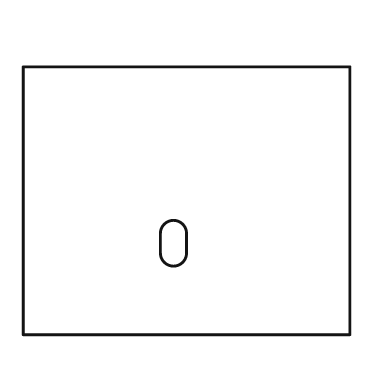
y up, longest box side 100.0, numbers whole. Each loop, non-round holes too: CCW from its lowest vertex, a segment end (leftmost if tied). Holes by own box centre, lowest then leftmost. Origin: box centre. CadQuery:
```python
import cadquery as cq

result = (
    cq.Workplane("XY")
    .moveTo(-50.0, -41.0)
    .lineTo(50.0, -41.0)
    .lineTo(50.0, 41.0)
    .lineTo(-50.0, 41.0)
    .close()
    .moveTo(-8.0, -16.0)
    .threePointArc((-4.0, -20.0), (0.0, -16.0))
    .lineTo(0.0, -10.0)
    .threePointArc((-4.0, -6.0), (-8.0, -10.0))
    .close()
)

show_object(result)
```